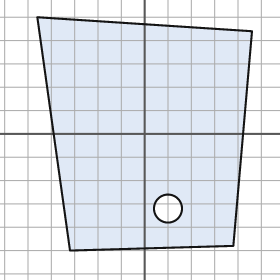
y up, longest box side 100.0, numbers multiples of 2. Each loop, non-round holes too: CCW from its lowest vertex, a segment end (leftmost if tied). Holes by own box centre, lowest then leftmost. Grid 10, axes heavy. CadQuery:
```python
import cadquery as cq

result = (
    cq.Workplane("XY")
    .moveTo(-32.0, -50.0)
    .lineTo(38.0, -48.0)
    .lineTo(46.0, 44.0)
    .lineTo(-46.0, 50.0)
    .close()
    .moveTo(10.0, -32.0)
    .circle(6.0)
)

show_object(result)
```